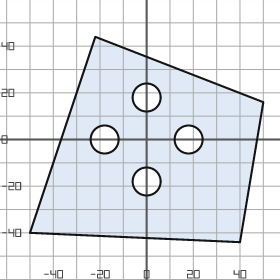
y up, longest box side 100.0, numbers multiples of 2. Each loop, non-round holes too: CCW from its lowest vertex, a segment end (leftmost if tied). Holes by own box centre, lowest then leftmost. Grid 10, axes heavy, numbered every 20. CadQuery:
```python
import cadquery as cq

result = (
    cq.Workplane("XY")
    .moveTo(40.0, -44.0)
    .lineTo(50.0, 16.0)
    .lineTo(-22.0, 44.0)
    .lineTo(-50.0, -40.0)
    .close()
    .moveTo(0.0, -18.0)
    .circle(6.0)
    .moveTo(-18.0, 0.0)
    .circle(6.0)
    .moveTo(18.0, 0.0)
    .circle(6.0)
    .moveTo(0.0, 18.0)
    .circle(6.0)
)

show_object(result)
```